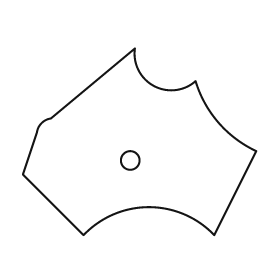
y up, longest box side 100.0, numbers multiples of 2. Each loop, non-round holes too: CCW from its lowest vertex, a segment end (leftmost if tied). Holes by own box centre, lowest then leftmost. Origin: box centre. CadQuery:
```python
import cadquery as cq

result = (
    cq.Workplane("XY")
    .moveTo(-24.0, -40.0)
    .threePointArc((4.0, -28.0), (32.0, -40.0))
    .lineTo(50.0, -4.0)
    .threePointArc((34.0, 8.0), (24.0, 26.0))
    .threePointArc((6.0, 24.0), (-2.0, 40.0))
    .lineTo(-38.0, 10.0)
    .threePointArc((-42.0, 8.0), (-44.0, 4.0))
    .lineTo(-50.0, -14.0)
    .close()
    .moveTo(-4.0, -8.0)
    .circle(4.0)
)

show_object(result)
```